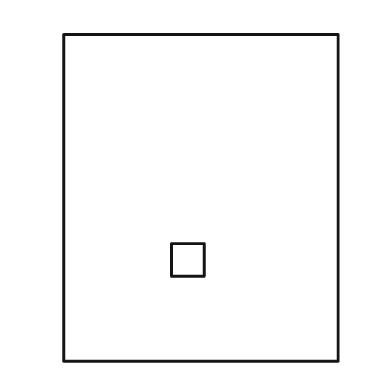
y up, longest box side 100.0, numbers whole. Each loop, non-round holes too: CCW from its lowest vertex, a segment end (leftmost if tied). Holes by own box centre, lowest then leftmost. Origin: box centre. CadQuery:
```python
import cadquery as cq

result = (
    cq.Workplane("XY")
    .moveTo(-42.0, -50.0)
    .lineTo(42.0, -50.0)
    .lineTo(42.0, 50.0)
    .lineTo(-42.0, 50.0)
    .close()
    .moveTo(-9.0, -24.0)
    .lineTo(1.0, -24.0)
    .lineTo(1.0, -14.0)
    .lineTo(-9.0, -14.0)
    .close()
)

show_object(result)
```